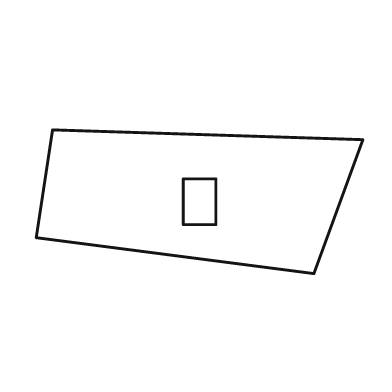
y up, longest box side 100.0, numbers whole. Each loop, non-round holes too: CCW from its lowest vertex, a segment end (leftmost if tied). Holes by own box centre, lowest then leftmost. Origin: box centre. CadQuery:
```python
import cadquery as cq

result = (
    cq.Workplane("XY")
    .moveTo(35.0, -22.0)
    .lineTo(50.0, 19.0)
    .lineTo(-45.0, 22.0)
    .lineTo(-50.0, -11.0)
    .close()
    .moveTo(-5.0, -7.0)
    .lineTo(5.0, -7.0)
    .lineTo(5.0, 7.0)
    .lineTo(-5.0, 7.0)
    .close()
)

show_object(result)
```